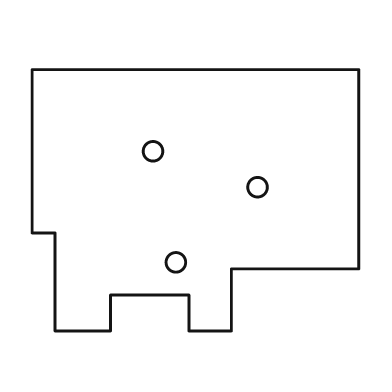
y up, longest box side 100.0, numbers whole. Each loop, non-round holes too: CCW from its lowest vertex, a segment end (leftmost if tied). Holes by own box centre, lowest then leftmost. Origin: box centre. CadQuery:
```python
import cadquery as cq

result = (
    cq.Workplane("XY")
    .moveTo(-43.0, -40.0)
    .lineTo(-26.0, -40.0)
    .lineTo(-26.0, -29.0)
    .lineTo(-2.0, -29.0)
    .lineTo(-2.0, -40.0)
    .lineTo(11.0, -40.0)
    .lineTo(11.0, -21.0)
    .lineTo(50.0, -21.0)
    .lineTo(50.0, 40.0)
    .lineTo(-50.0, 40.0)
    .lineTo(-50.0, -10.0)
    .lineTo(-43.0, -10.0)
    .close()
    .moveTo(-6.0, -19.0)
    .circle(3.0)
    .moveTo(19.0, 4.0)
    .circle(3.0)
    .moveTo(-13.0, 15.0)
    .circle(3.0)
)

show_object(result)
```